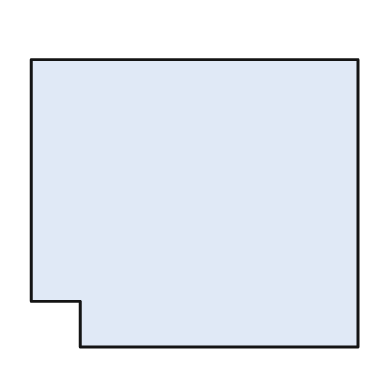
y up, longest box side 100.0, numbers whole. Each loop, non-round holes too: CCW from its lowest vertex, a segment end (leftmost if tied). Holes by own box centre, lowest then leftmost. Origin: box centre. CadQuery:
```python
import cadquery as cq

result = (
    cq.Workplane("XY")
    .moveTo(-35.0, -44.0)
    .lineTo(50.0, -44.0)
    .lineTo(50.0, 44.0)
    .lineTo(-50.0, 44.0)
    .lineTo(-50.0, -30.0)
    .lineTo(-35.0, -30.0)
    .close()
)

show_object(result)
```